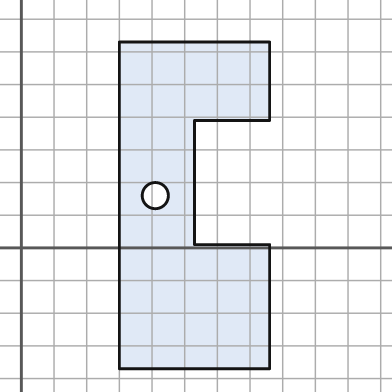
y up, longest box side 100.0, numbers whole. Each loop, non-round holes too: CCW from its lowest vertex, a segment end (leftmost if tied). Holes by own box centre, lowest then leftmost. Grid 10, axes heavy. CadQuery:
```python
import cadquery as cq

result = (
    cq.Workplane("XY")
    .moveTo(30.0, -37.0)
    .lineTo(76.0, -37.0)
    .lineTo(76.0, 1.0)
    .lineTo(53.0, 1.0)
    .lineTo(53.0, 39.0)
    .lineTo(76.0, 39.0)
    .lineTo(76.0, 63.0)
    .lineTo(30.0, 63.0)
    .close()
    .moveTo(41.0, 16.0)
    .circle(4.0)
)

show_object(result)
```